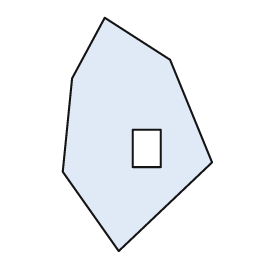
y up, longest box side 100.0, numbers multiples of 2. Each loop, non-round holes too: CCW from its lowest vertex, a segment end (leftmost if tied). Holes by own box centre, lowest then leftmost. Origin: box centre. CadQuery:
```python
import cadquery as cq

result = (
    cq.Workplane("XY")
    .moveTo(-8.0, -50.0)
    .lineTo(32.0, -12.0)
    .lineTo(14.0, 32.0)
    .lineTo(-14.0, 50.0)
    .lineTo(-28.0, 24.0)
    .lineTo(-32.0, -16.0)
    .close()
    .moveTo(-2.0, -14.0)
    .lineTo(10.0, -14.0)
    .lineTo(10.0, 2.0)
    .lineTo(-2.0, 2.0)
    .close()
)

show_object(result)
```